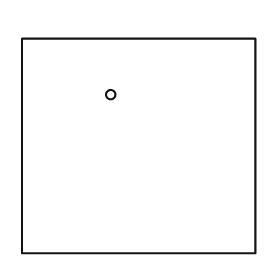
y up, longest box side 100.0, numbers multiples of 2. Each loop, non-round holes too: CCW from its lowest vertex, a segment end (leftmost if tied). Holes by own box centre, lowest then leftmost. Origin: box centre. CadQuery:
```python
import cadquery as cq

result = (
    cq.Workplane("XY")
    .moveTo(-50.0, -46.0)
    .lineTo(50.0, -46.0)
    .lineTo(50.0, 46.0)
    .lineTo(-50.0, 46.0)
    .close()
    .moveTo(-12.0, 22.0)
    .circle(2.0)
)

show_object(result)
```